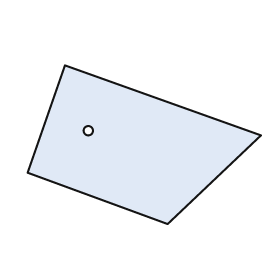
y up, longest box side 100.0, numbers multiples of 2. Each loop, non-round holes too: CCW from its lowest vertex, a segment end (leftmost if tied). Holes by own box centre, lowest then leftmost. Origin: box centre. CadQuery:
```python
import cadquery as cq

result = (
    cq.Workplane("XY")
    .moveTo(10.0, -34.0)
    .lineTo(50.0, 4.0)
    .lineTo(-34.0, 34.0)
    .lineTo(-50.0, -12.0)
    .close()
    .moveTo(-24.0, 6.0)
    .circle(2.0)
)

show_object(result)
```